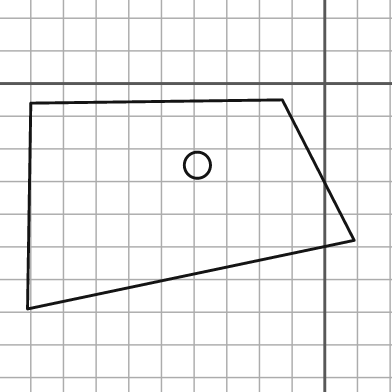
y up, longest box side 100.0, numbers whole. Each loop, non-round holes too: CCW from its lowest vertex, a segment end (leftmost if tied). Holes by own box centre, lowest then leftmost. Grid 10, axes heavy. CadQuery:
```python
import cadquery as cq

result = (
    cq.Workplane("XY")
    .moveTo(-91.0, -69.0)
    .lineTo(9.0, -48.0)
    .lineTo(-13.0, -5.0)
    .lineTo(-90.0, -6.0)
    .close()
    .moveTo(-39.0, -25.0)
    .circle(4.0)
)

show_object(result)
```